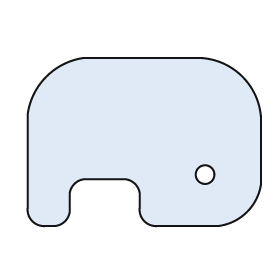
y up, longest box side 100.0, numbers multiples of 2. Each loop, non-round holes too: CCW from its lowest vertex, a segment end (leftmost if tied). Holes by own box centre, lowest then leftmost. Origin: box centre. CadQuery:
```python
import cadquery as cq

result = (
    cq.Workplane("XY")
    .moveTo(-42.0, -36.0)
    .lineTo(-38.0, -36.0)
    .threePointArc((-34.0, -34.0), (-32.0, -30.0))
    .lineTo(-32.0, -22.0)
    .threePointArc((-30.0, -18.0), (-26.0, -16.0))
    .lineTo(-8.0, -16.0)
    .threePointArc((-4.0, -18.0), (-2.0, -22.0))
    .lineTo(-2.0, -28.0)
    .threePointArc((0.0, -34.0), (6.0, -36.0))
    .lineTo(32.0, -36.0)
    .threePointArc((44.0, -30.0), (50.0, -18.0))
    .lineTo(50.0, 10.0)
    .threePointArc((42.0, 28.0), (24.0, 36.0))
    .lineTo(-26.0, 36.0)
    .threePointArc((-42.0, 28.0), (-50.0, 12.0))
    .lineTo(-50.0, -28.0)
    .threePointArc((-48.0, -34.0), (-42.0, -36.0))
    .close()
    .moveTo(26.0, -14.0)
    .circle(4.0)
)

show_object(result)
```